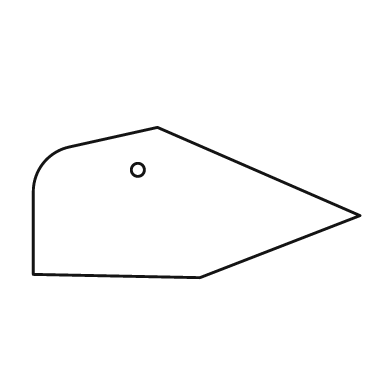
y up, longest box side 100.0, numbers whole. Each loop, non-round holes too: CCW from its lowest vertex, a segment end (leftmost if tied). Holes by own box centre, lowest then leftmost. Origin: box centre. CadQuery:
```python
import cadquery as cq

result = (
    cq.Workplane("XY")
    .moveTo(1.0, -23.0)
    .lineTo(50.0, -4.0)
    .lineTo(-12.0, 23.0)
    .lineTo(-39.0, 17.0)
    .threePointArc((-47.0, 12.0), (-50.0, 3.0))
    .lineTo(-50.0, -22.0)
    .close()
    .moveTo(-18.0, 10.0)
    .circle(2.0)
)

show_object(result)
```